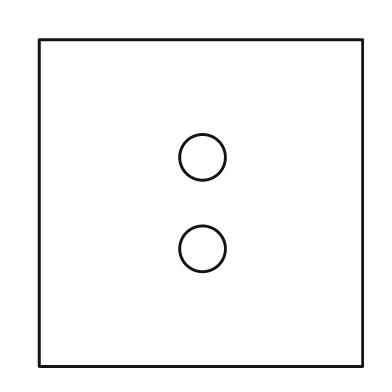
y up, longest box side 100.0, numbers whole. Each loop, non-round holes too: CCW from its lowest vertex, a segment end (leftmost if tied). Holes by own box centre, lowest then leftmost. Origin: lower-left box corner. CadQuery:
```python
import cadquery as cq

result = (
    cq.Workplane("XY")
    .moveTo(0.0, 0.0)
    .lineTo(99.0, 0.0)
    .lineTo(99.0, 100.0)
    .lineTo(0.0, 100.0)
    .close()
    .moveTo(50.0, 36.0)
    .circle(7.0)
    .moveTo(50.0, 64.0)
    .circle(7.0)
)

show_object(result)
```